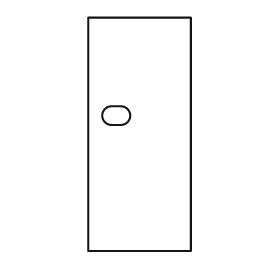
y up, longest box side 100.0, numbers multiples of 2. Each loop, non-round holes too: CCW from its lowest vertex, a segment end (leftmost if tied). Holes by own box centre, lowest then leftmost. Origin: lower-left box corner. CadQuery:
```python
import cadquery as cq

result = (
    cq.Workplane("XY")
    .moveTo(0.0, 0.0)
    .lineTo(44.0, 0.0)
    .lineTo(44.0, 100.0)
    .lineTo(0.0, 100.0)
    .close()
    .moveTo(10.0, 54.0)
    .lineTo(14.0, 54.0)
    .threePointArc((18.0, 58.0), (14.0, 62.0))
    .lineTo(10.0, 62.0)
    .threePointArc((6.0, 58.0), (10.0, 54.0))
    .close()
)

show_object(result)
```